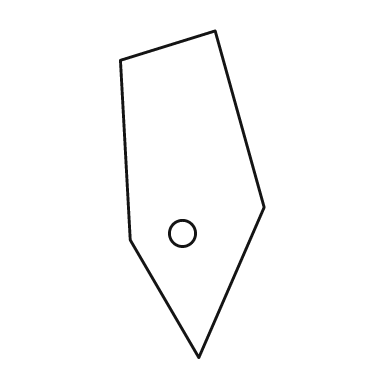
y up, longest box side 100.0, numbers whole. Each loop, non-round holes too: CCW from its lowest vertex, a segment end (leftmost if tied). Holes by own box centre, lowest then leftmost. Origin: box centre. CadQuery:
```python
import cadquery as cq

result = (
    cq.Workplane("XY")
    .moveTo(2.0, -50.0)
    .lineTo(22.0, -4.0)
    .lineTo(7.0, 50.0)
    .lineTo(-22.0, 41.0)
    .lineTo(-19.0, -14.0)
    .close()
    .moveTo(-3.0, -12.0)
    .circle(4.0)
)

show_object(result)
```